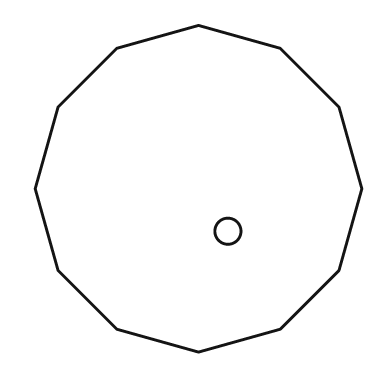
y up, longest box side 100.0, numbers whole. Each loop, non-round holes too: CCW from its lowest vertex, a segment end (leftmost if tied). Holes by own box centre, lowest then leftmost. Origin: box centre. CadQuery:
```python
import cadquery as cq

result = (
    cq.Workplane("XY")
    .moveTo(0.0, -50.0)
    .lineTo(25.0, -43.0)
    .lineTo(43.0, -25.0)
    .lineTo(50.0, 0.0)
    .lineTo(43.0, 25.0)
    .lineTo(25.0, 43.0)
    .lineTo(0.0, 50.0)
    .lineTo(-25.0, 43.0)
    .lineTo(-43.0, 25.0)
    .lineTo(-50.0, 0.0)
    .lineTo(-43.0, -25.0)
    .lineTo(-25.0, -43.0)
    .close()
    .moveTo(9.0, -13.0)
    .circle(4.0)
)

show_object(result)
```